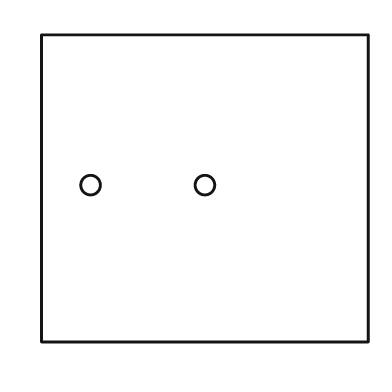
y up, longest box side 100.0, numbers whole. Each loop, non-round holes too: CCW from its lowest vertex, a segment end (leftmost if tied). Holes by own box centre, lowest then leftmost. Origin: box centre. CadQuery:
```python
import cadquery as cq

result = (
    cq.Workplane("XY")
    .moveTo(-50.0, -47.0)
    .lineTo(50.0, -47.0)
    .lineTo(50.0, 47.0)
    .lineTo(-50.0, 47.0)
    .close()
    .moveTo(-35.0, 1.0)
    .circle(3.0)
    .moveTo(0.0, 1.0)
    .circle(3.0)
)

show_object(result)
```